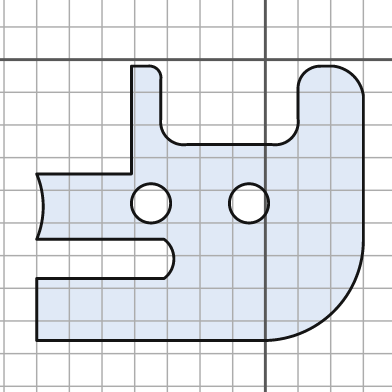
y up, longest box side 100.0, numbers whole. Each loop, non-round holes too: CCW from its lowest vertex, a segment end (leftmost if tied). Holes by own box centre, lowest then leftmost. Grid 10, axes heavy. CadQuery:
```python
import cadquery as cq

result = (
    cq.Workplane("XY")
    .moveTo(-70.0, -86.0)
    .lineTo(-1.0, -86.0)
    .threePointArc((21.0, -77.0), (30.0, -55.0))
    .lineTo(30.0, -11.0)
    .threePointArc((27.0, -5.0), (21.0, -2.0))
    .lineTo(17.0, -2.0)
    .threePointArc((12.0, -4.0), (10.0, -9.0))
    .lineTo(10.0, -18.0)
    .threePointArc((8.0, -24.0), (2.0, -26.0))
    .lineTo(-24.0, -26.0)
    .threePointArc((-30.0, -24.0), (-32.0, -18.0))
    .lineTo(-32.0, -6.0)
    .threePointArc((-33.0, -3.0), (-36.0, -2.0))
    .lineTo(-41.0, -2.0)
    .lineTo(-41.0, -35.0)
    .lineTo(-70.0, -35.0)
    .threePointArc((-68.0, -45.0), (-70.0, -55.0))
    .lineTo(-31.0, -55.0)
    .threePointArc((-28.0, -61.0), (-31.0, -67.0))
    .lineTo(-70.0, -67.0)
    .close()
    .moveTo(-35.0, -44.0)
    .circle(6.0)
    .moveTo(-5.0, -44.0)
    .circle(6.0)
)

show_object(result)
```